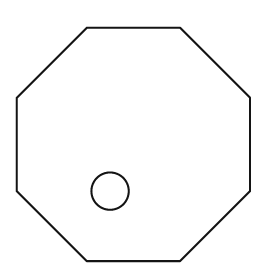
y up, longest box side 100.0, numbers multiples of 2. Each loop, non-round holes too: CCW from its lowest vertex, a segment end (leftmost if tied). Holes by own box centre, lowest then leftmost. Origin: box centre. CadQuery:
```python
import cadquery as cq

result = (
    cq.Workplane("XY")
    .moveTo(-20.0, -50.0)
    .lineTo(20.0, -50.0)
    .lineTo(50.0, -20.0)
    .lineTo(50.0, 20.0)
    .lineTo(20.0, 50.0)
    .lineTo(-20.0, 50.0)
    .lineTo(-50.0, 20.0)
    .lineTo(-50.0, -20.0)
    .close()
    .moveTo(-10.0, -20.0)
    .circle(8.0)
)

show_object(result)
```